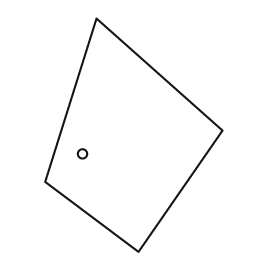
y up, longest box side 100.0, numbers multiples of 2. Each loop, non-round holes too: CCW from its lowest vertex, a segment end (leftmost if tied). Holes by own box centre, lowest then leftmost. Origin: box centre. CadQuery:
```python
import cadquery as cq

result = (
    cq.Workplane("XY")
    .moveTo(2.0, -50.0)
    .lineTo(38.0, 2.0)
    .lineTo(-16.0, 50.0)
    .lineTo(-38.0, -20.0)
    .close()
    .moveTo(-22.0, -8.0)
    .circle(2.0)
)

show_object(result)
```